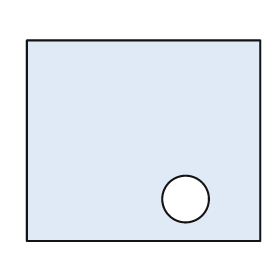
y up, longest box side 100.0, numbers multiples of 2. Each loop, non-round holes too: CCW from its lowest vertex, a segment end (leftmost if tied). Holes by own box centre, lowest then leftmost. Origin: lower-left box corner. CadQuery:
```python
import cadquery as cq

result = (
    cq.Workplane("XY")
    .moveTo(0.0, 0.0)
    .lineTo(100.0, 0.0)
    .lineTo(100.0, 86.0)
    .lineTo(0.0, 86.0)
    .close()
    .moveTo(68.0, 18.0)
    .circle(10.0)
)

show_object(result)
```